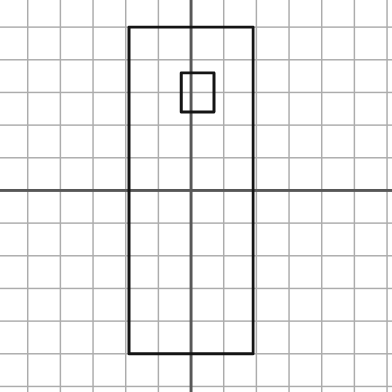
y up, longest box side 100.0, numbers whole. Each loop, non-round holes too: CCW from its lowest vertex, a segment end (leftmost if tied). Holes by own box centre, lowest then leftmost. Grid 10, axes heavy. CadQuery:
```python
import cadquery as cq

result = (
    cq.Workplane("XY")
    .moveTo(-19.0, -50.0)
    .lineTo(19.0, -50.0)
    .lineTo(19.0, 50.0)
    .lineTo(-19.0, 50.0)
    .close()
    .moveTo(-3.0, 24.0)
    .lineTo(7.0, 24.0)
    .lineTo(7.0, 36.0)
    .lineTo(-3.0, 36.0)
    .close()
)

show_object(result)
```